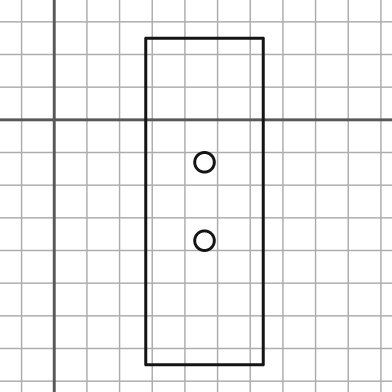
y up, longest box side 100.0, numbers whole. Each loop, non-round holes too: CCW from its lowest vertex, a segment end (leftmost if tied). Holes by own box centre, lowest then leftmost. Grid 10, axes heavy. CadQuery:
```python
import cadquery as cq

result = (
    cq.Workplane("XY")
    .moveTo(28.0, -75.0)
    .lineTo(64.0, -75.0)
    .lineTo(64.0, 25.0)
    .lineTo(28.0, 25.0)
    .close()
    .moveTo(46.0, -37.0)
    .circle(3.0)
    .moveTo(46.0, -13.0)
    .circle(3.0)
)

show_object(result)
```